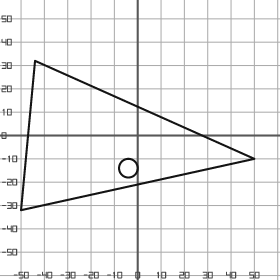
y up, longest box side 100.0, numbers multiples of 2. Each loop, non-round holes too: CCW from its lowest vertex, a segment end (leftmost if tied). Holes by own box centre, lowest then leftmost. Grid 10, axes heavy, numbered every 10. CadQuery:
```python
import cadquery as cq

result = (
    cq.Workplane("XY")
    .moveTo(-50.0, -32.0)
    .lineTo(50.0, -10.0)
    .lineTo(-44.0, 32.0)
    .close()
    .moveTo(-4.0, -14.0)
    .circle(4.0)
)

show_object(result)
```